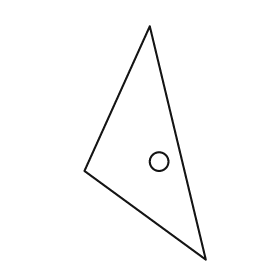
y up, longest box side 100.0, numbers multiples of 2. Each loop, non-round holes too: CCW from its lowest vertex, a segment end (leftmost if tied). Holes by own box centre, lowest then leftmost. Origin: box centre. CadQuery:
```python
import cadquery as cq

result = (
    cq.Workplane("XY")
    .moveTo(26.0, -50.0)
    .lineTo(2.0, 50.0)
    .lineTo(-26.0, -12.0)
    .close()
    .moveTo(6.0, -8.0)
    .circle(4.0)
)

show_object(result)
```